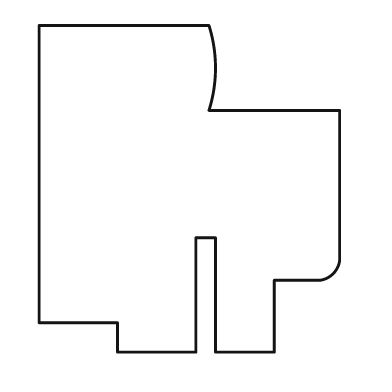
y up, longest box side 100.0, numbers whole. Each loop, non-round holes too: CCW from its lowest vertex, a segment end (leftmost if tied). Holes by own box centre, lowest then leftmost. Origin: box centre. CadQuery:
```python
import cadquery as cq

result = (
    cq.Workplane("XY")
    .moveTo(-22.0, -50.0)
    .lineTo(2.0, -50.0)
    .lineTo(2.0, -15.0)
    .lineTo(8.0, -15.0)
    .lineTo(8.0, -50.0)
    .lineTo(26.0, -50.0)
    .lineTo(26.0, -28.0)
    .lineTo(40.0, -28.0)
    .threePointArc((44.0, -26.0), (46.0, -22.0))
    .lineTo(46.0, 24.0)
    .lineTo(6.0, 24.0)
    .threePointArc((8.0, 37.0), (6.0, 50.0))
    .lineTo(-46.0, 50.0)
    .lineTo(-46.0, -41.0)
    .lineTo(-22.0, -41.0)
    .close()
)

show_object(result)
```